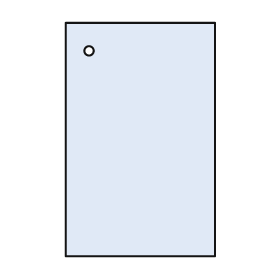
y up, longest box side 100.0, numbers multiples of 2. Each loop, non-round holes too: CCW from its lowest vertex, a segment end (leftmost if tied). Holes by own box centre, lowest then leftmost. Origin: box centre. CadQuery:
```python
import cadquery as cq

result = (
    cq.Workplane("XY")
    .moveTo(-32.0, -50.0)
    .lineTo(32.0, -50.0)
    .lineTo(32.0, 50.0)
    .lineTo(-32.0, 50.0)
    .close()
    .moveTo(-22.0, 38.0)
    .circle(2.0)
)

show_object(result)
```